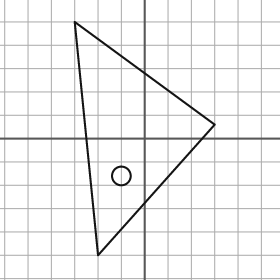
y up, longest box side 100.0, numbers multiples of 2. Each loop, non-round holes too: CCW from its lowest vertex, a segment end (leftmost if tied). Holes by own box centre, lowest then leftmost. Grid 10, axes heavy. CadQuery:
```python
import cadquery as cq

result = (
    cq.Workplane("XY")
    .moveTo(-20.0, -50.0)
    .lineTo(30.0, 6.0)
    .lineTo(-30.0, 50.0)
    .close()
    .moveTo(-10.0, -16.0)
    .circle(4.0)
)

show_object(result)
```